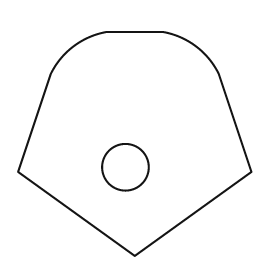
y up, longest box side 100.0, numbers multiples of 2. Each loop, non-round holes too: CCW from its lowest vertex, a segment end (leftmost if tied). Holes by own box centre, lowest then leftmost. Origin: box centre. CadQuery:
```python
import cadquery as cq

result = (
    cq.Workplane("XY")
    .moveTo(0.0, -48.0)
    .lineTo(50.0, -12.0)
    .lineTo(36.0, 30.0)
    .threePointArc((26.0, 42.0), (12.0, 48.0))
    .lineTo(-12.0, 48.0)
    .threePointArc((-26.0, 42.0), (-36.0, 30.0))
    .lineTo(-50.0, -12.0)
    .close()
    .moveTo(-4.0, -10.0)
    .circle(10.0)
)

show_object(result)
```